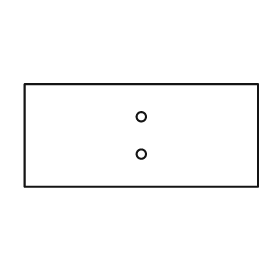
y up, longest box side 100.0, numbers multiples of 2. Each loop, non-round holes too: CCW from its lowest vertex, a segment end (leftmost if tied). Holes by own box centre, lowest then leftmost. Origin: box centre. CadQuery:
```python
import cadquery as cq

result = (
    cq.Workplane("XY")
    .moveTo(-50.0, -22.0)
    .lineTo(50.0, -22.0)
    .lineTo(50.0, 22.0)
    .lineTo(-50.0, 22.0)
    .close()
    .moveTo(0.0, -8.0)
    .circle(2.0)
    .moveTo(0.0, 8.0)
    .circle(2.0)
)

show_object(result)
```